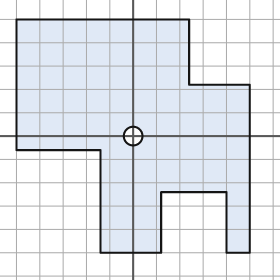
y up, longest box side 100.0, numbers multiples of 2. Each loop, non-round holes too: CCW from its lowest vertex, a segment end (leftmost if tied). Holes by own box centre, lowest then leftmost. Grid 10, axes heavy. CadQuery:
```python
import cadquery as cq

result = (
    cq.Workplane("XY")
    .moveTo(-14.0, -50.0)
    .lineTo(12.0, -50.0)
    .lineTo(12.0, -24.0)
    .lineTo(40.0, -24.0)
    .lineTo(40.0, -50.0)
    .lineTo(50.0, -50.0)
    .lineTo(50.0, 22.0)
    .lineTo(24.0, 22.0)
    .lineTo(24.0, 50.0)
    .lineTo(-50.0, 50.0)
    .lineTo(-50.0, -6.0)
    .lineTo(-14.0, -6.0)
    .close()
    .moveTo(0.0, 0.0)
    .circle(4.0)
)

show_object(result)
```